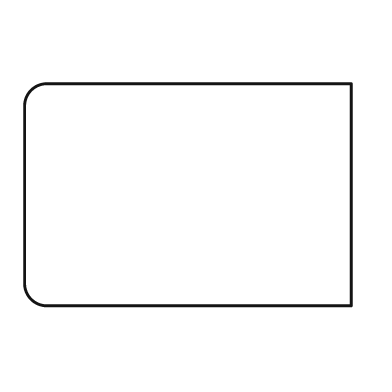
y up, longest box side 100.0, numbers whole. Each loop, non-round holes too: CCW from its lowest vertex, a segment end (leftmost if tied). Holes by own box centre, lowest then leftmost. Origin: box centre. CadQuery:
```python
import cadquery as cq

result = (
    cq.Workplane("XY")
    .moveTo(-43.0, -34.0)
    .lineTo(50.0, -34.0)
    .lineTo(50.0, 34.0)
    .lineTo(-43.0, 34.0)
    .threePointArc((-48.0, 32.0), (-50.0, 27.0))
    .lineTo(-50.0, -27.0)
    .threePointArc((-48.0, -32.0), (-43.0, -34.0))
    .close()
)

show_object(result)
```